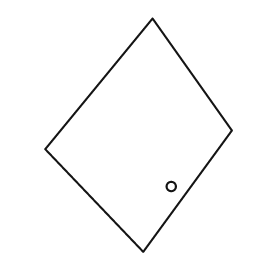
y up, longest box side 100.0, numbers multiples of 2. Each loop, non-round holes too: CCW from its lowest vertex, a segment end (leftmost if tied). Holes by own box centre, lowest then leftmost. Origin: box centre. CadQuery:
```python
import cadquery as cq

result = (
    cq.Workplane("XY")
    .moveTo(2.0, -50.0)
    .lineTo(40.0, 2.0)
    .lineTo(6.0, 50.0)
    .lineTo(-40.0, -6.0)
    .close()
    .moveTo(14.0, -22.0)
    .circle(2.0)
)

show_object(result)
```